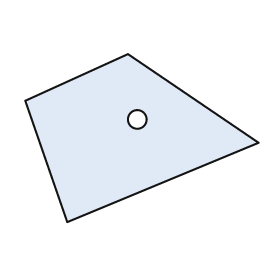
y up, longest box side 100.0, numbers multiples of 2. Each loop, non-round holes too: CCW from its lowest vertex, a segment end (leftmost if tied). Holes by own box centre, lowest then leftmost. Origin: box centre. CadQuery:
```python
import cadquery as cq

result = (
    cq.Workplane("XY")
    .moveTo(-32.0, -36.0)
    .lineTo(50.0, -2.0)
    .lineTo(-6.0, 36.0)
    .lineTo(-50.0, 16.0)
    .close()
    .moveTo(-2.0, 8.0)
    .circle(4.0)
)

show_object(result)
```